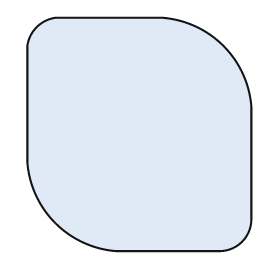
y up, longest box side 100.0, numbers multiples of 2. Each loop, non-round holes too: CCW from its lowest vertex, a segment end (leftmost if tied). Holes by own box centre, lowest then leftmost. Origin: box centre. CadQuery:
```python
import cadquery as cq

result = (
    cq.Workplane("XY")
    .moveTo(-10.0, -50.0)
    .lineTo(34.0, -50.0)
    .threePointArc((44.0, -46.0), (48.0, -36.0))
    .lineTo(48.0, 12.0)
    .threePointArc((36.0, 38.0), (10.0, 50.0))
    .lineTo(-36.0, 50.0)
    .threePointArc((-44.0, 46.0), (-48.0, 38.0))
    .lineTo(-48.0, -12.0)
    .threePointArc((-36.0, -38.0), (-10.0, -50.0))
    .close()
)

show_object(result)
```